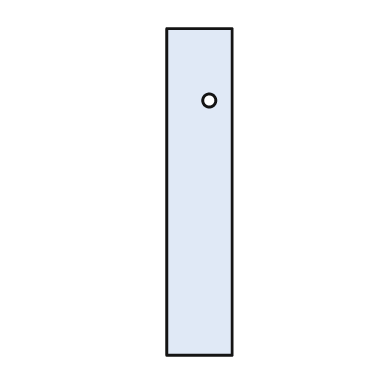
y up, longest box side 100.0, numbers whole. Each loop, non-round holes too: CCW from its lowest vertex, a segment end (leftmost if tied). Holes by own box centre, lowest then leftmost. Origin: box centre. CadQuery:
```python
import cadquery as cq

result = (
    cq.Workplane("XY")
    .moveTo(-10.0, -50.0)
    .lineTo(10.0, -50.0)
    .lineTo(10.0, 50.0)
    .lineTo(-10.0, 50.0)
    .close()
    .moveTo(3.0, 28.0)
    .circle(2.0)
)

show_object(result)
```